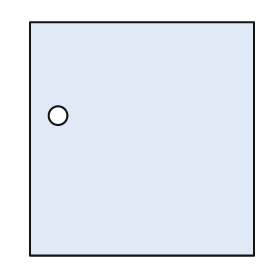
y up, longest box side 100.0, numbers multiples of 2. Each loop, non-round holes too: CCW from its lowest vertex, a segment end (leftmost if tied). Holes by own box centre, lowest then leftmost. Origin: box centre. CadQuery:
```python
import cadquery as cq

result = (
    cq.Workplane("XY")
    .moveTo(-48.0, -50.0)
    .lineTo(48.0, -50.0)
    .lineTo(48.0, 50.0)
    .lineTo(-48.0, 50.0)
    .close()
    .moveTo(-36.0, 10.0)
    .circle(4.0)
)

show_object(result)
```